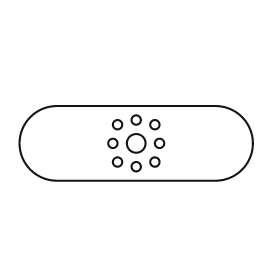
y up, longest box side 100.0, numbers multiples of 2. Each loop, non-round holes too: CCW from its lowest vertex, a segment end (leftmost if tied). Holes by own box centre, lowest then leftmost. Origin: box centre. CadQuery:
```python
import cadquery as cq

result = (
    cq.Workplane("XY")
    .moveTo(-34.0, -16.0)
    .lineTo(34.0, -16.0)
    .threePointArc((50.0, 0.0), (34.0, 16.0))
    .lineTo(-34.0, 16.0)
    .threePointArc((-50.0, 0.0), (-34.0, -16.0))
    .close()
    .moveTo(0.0, -10.0)
    .circle(2.0)
    .moveTo(-8.0, -8.0)
    .circle(2.0)
    .moveTo(8.0, -8.0)
    .circle(2.0)
    .moveTo(-10.0, 0.0)
    .circle(2.0)
    .moveTo(0.0, 0.0)
    .circle(4.0)
    .moveTo(10.0, 0.0)
    .circle(2.0)
    .moveTo(-8.0, 8.0)
    .circle(2.0)
    .moveTo(8.0, 8.0)
    .circle(2.0)
    .moveTo(0.0, 10.0)
    .circle(2.0)
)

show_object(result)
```